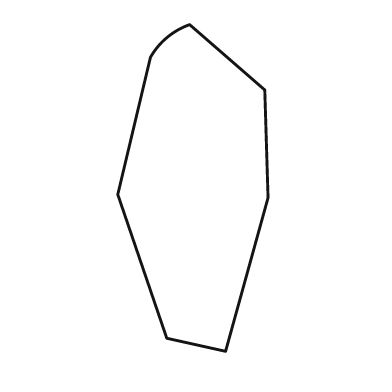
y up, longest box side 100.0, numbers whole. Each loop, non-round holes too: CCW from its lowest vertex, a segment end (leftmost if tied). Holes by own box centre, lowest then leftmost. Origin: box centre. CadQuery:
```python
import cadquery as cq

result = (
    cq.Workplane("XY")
    .moveTo(10.0, -50.0)
    .lineTo(23.0, -3.0)
    .lineTo(22.0, 30.0)
    .lineTo(-1.0, 50.0)
    .threePointArc((-8.0, 46.0), (-13.0, 40.0))
    .lineTo(-23.0, -2.0)
    .lineTo(-8.0, -46.0)
    .close()
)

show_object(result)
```